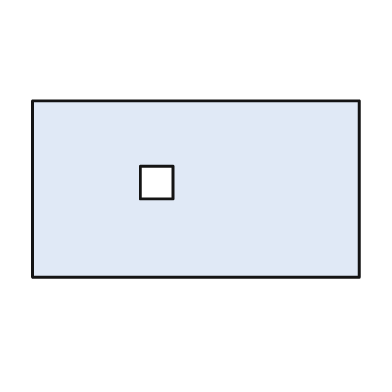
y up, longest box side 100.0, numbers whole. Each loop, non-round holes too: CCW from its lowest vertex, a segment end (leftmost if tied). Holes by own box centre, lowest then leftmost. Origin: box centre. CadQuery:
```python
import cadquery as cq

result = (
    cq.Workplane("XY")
    .moveTo(-50.0, -27.0)
    .lineTo(50.0, -27.0)
    .lineTo(50.0, 27.0)
    .lineTo(-50.0, 27.0)
    .close()
    .moveTo(-17.0, -3.0)
    .lineTo(-7.0, -3.0)
    .lineTo(-7.0, 7.0)
    .lineTo(-17.0, 7.0)
    .close()
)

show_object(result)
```